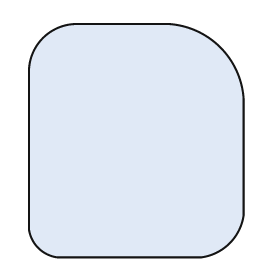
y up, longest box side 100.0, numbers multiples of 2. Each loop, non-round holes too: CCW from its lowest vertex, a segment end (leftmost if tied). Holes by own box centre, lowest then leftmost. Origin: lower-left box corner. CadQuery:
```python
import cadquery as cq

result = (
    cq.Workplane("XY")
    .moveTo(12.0, 0.0)
    .lineTo(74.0, 0.0)
    .threePointArc((86.0, 6.0), (92.0, 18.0))
    .lineTo(92.0, 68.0)
    .threePointArc((82.0, 90.0), (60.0, 100.0))
    .lineTo(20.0, 100.0)
    .threePointArc((6.0, 94.0), (0.0, 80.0))
    .lineTo(0.0, 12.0)
    .threePointArc((4.0, 4.0), (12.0, 0.0))
    .close()
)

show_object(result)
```